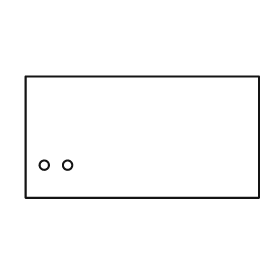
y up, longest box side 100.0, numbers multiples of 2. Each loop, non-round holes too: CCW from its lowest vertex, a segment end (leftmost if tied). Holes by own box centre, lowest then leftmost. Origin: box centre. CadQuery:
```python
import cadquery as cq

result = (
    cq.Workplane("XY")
    .moveTo(-50.0, -26.0)
    .lineTo(50.0, -26.0)
    .lineTo(50.0, 26.0)
    .lineTo(-50.0, 26.0)
    .close()
    .moveTo(-42.0, -12.0)
    .circle(2.0)
    .moveTo(-32.0, -12.0)
    .circle(2.0)
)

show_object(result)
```